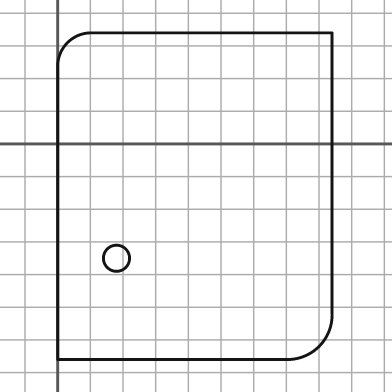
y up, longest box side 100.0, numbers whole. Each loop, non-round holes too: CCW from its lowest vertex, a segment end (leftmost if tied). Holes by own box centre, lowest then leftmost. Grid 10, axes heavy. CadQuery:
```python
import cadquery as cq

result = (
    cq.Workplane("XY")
    .moveTo(0.0, -66.0)
    .lineTo(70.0, -66.0)
    .threePointArc((80.0, -62.0), (84.0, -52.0))
    .lineTo(84.0, 34.0)
    .lineTo(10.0, 34.0)
    .threePointArc((3.0, 31.0), (0.0, 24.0))
    .close()
    .moveTo(18.0, -35.0)
    .circle(4.0)
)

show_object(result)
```